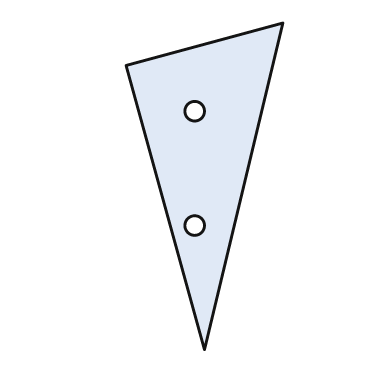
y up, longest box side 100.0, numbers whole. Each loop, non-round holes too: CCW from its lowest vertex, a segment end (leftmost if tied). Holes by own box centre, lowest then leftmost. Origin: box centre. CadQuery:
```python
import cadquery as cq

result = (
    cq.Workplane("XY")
    .moveTo(0.0, -50.0)
    .lineTo(24.0, 50.0)
    .lineTo(-24.0, 37.0)
    .close()
    .moveTo(-3.0, -12.0)
    .circle(3.0)
    .moveTo(-3.0, 23.0)
    .circle(3.0)
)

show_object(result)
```